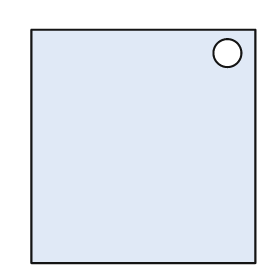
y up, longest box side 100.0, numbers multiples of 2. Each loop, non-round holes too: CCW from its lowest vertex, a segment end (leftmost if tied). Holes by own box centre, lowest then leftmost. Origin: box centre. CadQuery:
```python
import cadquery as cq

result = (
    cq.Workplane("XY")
    .moveTo(-48.0, -50.0)
    .lineTo(48.0, -50.0)
    .lineTo(48.0, 50.0)
    .lineTo(-48.0, 50.0)
    .close()
    .moveTo(36.0, 40.0)
    .circle(6.0)
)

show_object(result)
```